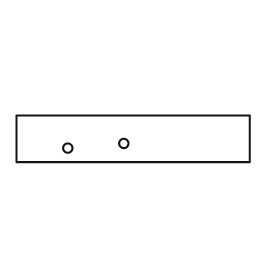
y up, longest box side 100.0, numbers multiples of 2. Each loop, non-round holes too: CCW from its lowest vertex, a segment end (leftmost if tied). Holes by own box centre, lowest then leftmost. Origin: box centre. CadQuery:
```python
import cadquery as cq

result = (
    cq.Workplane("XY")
    .moveTo(-50.0, -10.0)
    .lineTo(50.0, -10.0)
    .lineTo(50.0, 10.0)
    .lineTo(-50.0, 10.0)
    .close()
    .moveTo(-28.0, -4.0)
    .circle(2.0)
    .moveTo(-4.0, -2.0)
    .circle(2.0)
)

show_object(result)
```